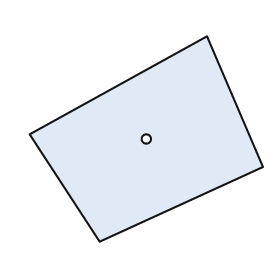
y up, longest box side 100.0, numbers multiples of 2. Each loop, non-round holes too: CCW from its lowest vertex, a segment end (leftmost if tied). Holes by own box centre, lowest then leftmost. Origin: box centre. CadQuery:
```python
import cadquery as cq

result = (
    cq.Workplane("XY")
    .moveTo(-20.0, -44.0)
    .lineTo(50.0, -12.0)
    .lineTo(26.0, 44.0)
    .lineTo(-50.0, 2.0)
    .close()
    .moveTo(0.0, 0.0)
    .circle(2.0)
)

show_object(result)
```